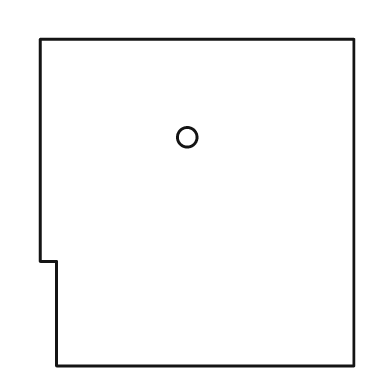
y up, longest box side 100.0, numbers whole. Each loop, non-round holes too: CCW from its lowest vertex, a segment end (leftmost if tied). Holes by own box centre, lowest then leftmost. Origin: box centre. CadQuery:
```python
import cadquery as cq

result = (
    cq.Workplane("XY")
    .moveTo(-43.0, -50.0)
    .lineTo(48.0, -50.0)
    .lineTo(48.0, 50.0)
    .lineTo(-48.0, 50.0)
    .lineTo(-48.0, -18.0)
    .lineTo(-43.0, -18.0)
    .close()
    .moveTo(-3.0, 20.0)
    .circle(3.0)
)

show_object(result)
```